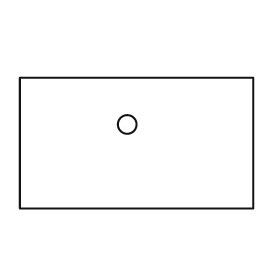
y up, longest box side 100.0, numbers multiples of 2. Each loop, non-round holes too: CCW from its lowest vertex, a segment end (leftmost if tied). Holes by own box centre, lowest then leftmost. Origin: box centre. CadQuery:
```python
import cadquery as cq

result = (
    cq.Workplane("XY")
    .moveTo(-50.0, -28.0)
    .lineTo(50.0, -28.0)
    .lineTo(50.0, 28.0)
    .lineTo(-50.0, 28.0)
    .close()
    .moveTo(-4.0, 8.0)
    .circle(4.0)
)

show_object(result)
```